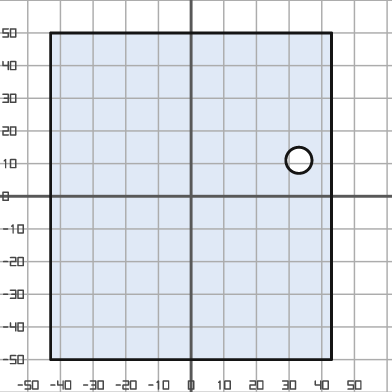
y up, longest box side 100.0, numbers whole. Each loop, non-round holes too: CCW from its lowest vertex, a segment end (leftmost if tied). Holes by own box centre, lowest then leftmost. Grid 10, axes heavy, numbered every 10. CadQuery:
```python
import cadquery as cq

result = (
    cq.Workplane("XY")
    .moveTo(-43.0, -50.0)
    .lineTo(43.0, -50.0)
    .lineTo(43.0, 50.0)
    .lineTo(-43.0, 50.0)
    .close()
    .moveTo(33.0, 11.0)
    .circle(4.0)
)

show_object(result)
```